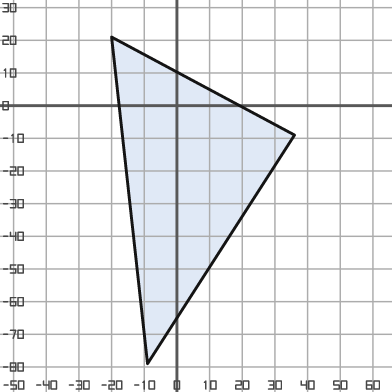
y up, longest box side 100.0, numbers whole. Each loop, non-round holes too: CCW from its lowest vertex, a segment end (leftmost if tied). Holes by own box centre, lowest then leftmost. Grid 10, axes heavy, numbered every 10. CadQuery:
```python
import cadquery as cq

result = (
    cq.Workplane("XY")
    .moveTo(-9.0, -79.0)
    .lineTo(36.0, -9.0)
    .lineTo(-20.0, 21.0)
    .close()
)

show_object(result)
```